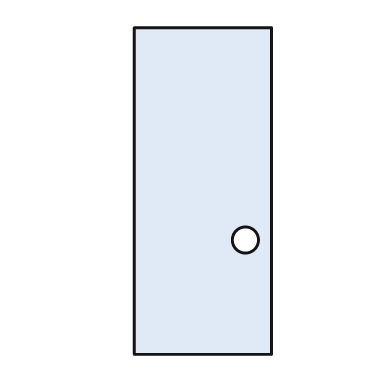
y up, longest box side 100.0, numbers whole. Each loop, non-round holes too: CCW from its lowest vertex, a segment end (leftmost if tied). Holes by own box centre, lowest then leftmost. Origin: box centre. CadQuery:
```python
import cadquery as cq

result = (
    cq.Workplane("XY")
    .moveTo(-21.0, -50.0)
    .lineTo(21.0, -50.0)
    .lineTo(21.0, 50.0)
    .lineTo(-21.0, 50.0)
    .close()
    .moveTo(13.0, -15.0)
    .circle(4.0)
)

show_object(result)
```